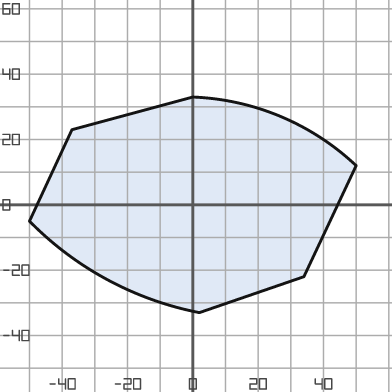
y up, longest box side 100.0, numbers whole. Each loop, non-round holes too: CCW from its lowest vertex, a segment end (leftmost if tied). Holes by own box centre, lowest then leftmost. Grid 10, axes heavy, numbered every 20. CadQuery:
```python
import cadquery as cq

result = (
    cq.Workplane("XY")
    .moveTo(2.0, -33.0)
    .lineTo(34.0, -22.0)
    .lineTo(50.0, 12.0)
    .threePointArc((27.0, 27.0), (0.0, 33.0))
    .lineTo(-37.0, 23.0)
    .lineTo(-50.0, -5.0)
    .threePointArc((-26.0, -23.0), (2.0, -33.0))
    .close()
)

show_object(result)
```